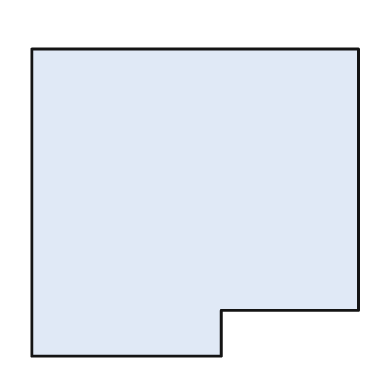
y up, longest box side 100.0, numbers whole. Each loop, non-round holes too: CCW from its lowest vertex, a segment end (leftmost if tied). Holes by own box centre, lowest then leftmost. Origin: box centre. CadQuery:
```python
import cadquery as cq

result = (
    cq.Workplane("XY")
    .moveTo(-50.0, -47.0)
    .lineTo(8.0, -47.0)
    .lineTo(8.0, -33.0)
    .lineTo(50.0, -33.0)
    .lineTo(50.0, 47.0)
    .lineTo(-50.0, 47.0)
    .close()
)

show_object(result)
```